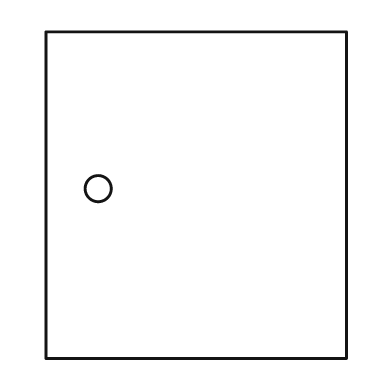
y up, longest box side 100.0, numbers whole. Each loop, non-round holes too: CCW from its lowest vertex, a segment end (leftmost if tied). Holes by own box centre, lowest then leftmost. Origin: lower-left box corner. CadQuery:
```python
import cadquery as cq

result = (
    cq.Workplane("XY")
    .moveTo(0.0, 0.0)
    .lineTo(92.0, 0.0)
    .lineTo(92.0, 100.0)
    .lineTo(0.0, 100.0)
    .close()
    .moveTo(16.0, 52.0)
    .circle(4.0)
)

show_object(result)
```